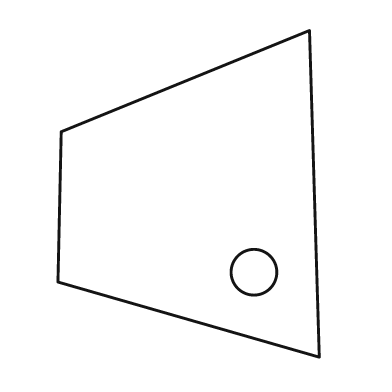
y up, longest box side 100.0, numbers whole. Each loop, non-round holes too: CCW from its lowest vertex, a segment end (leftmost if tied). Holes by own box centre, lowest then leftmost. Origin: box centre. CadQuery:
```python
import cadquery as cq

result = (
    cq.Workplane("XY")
    .moveTo(40.0, -50.0)
    .lineTo(37.0, 50.0)
    .lineTo(-39.0, 19.0)
    .lineTo(-40.0, -27.0)
    .close()
    .moveTo(20.0, -24.0)
    .circle(7.0)
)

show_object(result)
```